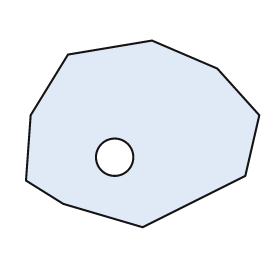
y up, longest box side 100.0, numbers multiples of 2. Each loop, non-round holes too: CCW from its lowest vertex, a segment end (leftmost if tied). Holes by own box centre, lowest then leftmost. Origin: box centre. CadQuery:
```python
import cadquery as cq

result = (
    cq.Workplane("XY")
    .moveTo(0.0, -40.0)
    .lineTo(44.0, -18.0)
    .lineTo(50.0, 8.0)
    .lineTo(32.0, 28.0)
    .lineTo(4.0, 40.0)
    .lineTo(-32.0, 34.0)
    .lineTo(-48.0, 8.0)
    .lineTo(-50.0, -20.0)
    .lineTo(-34.0, -30.0)
    .close()
    .moveTo(-12.0, -10.0)
    .circle(8.0)
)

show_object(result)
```